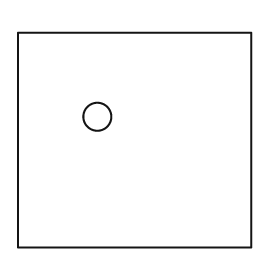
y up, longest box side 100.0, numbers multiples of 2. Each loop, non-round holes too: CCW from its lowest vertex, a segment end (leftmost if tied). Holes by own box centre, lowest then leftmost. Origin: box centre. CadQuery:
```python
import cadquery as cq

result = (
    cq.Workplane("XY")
    .moveTo(-50.0, -46.0)
    .lineTo(50.0, -46.0)
    .lineTo(50.0, 46.0)
    .lineTo(-50.0, 46.0)
    .close()
    .moveTo(-16.0, 10.0)
    .circle(6.0)
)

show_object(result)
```